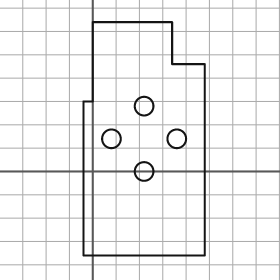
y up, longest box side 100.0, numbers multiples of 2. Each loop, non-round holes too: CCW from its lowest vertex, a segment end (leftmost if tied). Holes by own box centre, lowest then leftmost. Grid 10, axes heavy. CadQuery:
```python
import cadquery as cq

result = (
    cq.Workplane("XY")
    .moveTo(-4.0, -36.0)
    .lineTo(48.0, -36.0)
    .lineTo(48.0, 46.0)
    .lineTo(34.0, 46.0)
    .lineTo(34.0, 64.0)
    .lineTo(0.0, 64.0)
    .lineTo(0.0, 30.0)
    .lineTo(-4.0, 30.0)
    .close()
    .moveTo(22.0, 0.0)
    .circle(4.0)
    .moveTo(8.0, 14.0)
    .circle(4.0)
    .moveTo(36.0, 14.0)
    .circle(4.0)
    .moveTo(22.0, 28.0)
    .circle(4.0)
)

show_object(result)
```